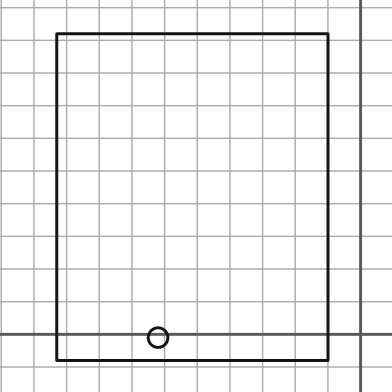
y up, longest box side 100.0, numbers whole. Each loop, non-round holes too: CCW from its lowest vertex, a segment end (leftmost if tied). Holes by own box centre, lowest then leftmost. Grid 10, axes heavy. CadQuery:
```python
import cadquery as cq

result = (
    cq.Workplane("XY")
    .moveTo(-93.0, -8.0)
    .lineTo(-10.0, -8.0)
    .lineTo(-10.0, 92.0)
    .lineTo(-93.0, 92.0)
    .close()
    .moveTo(-62.0, -1.0)
    .circle(3.0)
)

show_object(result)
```